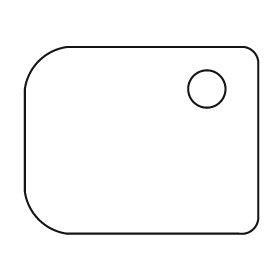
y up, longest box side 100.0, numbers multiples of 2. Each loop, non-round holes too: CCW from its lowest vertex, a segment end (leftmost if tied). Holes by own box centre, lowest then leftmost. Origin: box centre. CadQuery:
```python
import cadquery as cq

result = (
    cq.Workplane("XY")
    .moveTo(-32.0, -40.0)
    .lineTo(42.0, -40.0)
    .threePointArc((48.0, -38.0), (50.0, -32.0))
    .lineTo(50.0, 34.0)
    .threePointArc((48.0, 38.0), (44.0, 40.0))
    .lineTo(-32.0, 40.0)
    .threePointArc((-44.0, 34.0), (-50.0, 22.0))
    .lineTo(-50.0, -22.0)
    .threePointArc((-44.0, -34.0), (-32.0, -40.0))
    .close()
    .moveTo(28.0, 22.0)
    .circle(8.0)
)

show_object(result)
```